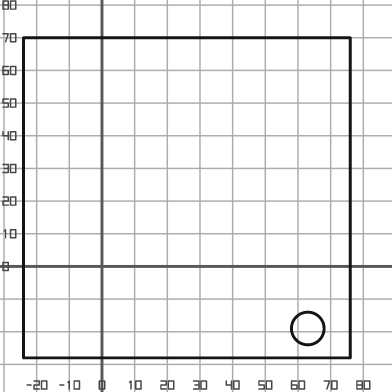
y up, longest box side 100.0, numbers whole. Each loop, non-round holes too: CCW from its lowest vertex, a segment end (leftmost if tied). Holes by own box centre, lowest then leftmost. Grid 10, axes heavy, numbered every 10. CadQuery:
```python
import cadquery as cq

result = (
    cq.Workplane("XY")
    .moveTo(-24.0, -28.0)
    .lineTo(76.0, -28.0)
    .lineTo(76.0, 70.0)
    .lineTo(-24.0, 70.0)
    .close()
    .moveTo(63.0, -19.0)
    .circle(5.0)
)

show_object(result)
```